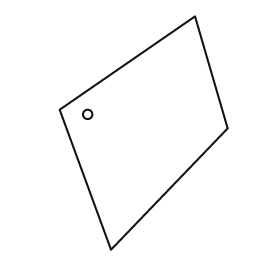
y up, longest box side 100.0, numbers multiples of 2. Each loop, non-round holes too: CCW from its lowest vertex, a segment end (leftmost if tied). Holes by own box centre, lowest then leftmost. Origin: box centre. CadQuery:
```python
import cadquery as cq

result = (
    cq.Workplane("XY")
    .moveTo(-14.0, -50.0)
    .lineTo(36.0, 2.0)
    .lineTo(22.0, 50.0)
    .lineTo(-36.0, 10.0)
    .close()
    .moveTo(-24.0, 8.0)
    .circle(2.0)
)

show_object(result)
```